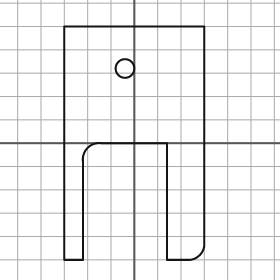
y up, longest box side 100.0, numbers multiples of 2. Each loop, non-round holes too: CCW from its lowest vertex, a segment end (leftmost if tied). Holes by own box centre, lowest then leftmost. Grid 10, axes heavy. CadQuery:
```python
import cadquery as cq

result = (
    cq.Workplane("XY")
    .moveTo(-30.0, -50.0)
    .lineTo(-22.0, -50.0)
    .lineTo(-22.0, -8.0)
    .threePointArc((-20.0, -2.0), (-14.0, 0.0))
    .lineTo(14.0, 0.0)
    .lineTo(14.0, -50.0)
    .lineTo(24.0, -50.0)
    .threePointArc((28.0, -48.0), (30.0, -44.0))
    .lineTo(30.0, 50.0)
    .lineTo(-30.0, 50.0)
    .close()
    .moveTo(-4.0, 32.0)
    .circle(4.0)
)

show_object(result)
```